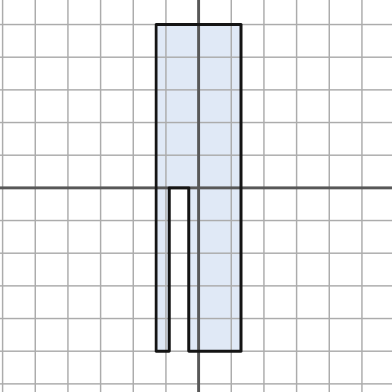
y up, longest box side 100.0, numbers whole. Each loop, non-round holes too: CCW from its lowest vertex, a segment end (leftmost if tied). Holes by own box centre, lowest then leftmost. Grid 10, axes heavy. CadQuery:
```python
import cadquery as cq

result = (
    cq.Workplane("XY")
    .moveTo(-13.0, -50.0)
    .lineTo(-9.0, -50.0)
    .lineTo(-9.0, 0.0)
    .lineTo(-3.0, 0.0)
    .lineTo(-3.0, -50.0)
    .lineTo(13.0, -50.0)
    .lineTo(13.0, 50.0)
    .lineTo(-13.0, 50.0)
    .close()
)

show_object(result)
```